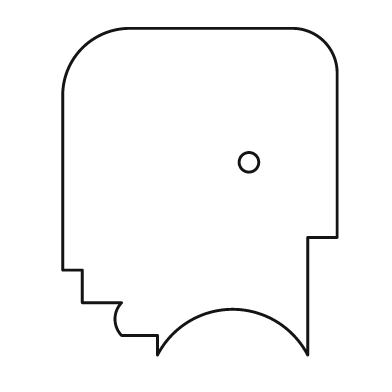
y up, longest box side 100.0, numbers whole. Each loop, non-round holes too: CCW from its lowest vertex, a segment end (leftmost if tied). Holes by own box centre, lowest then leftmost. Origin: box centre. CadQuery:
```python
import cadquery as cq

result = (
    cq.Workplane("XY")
    .moveTo(-13.0, -50.0)
    .threePointArc((10.0, -36.0), (33.0, -50.0))
    .lineTo(33.0, -14.0)
    .lineTo(42.0, -14.0)
    .lineTo(42.0, 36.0)
    .threePointArc((38.0, 46.0), (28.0, 50.0))
    .lineTo(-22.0, 50.0)
    .threePointArc((-36.0, 44.0), (-42.0, 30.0))
    .lineTo(-42.0, -24.0)
    .lineTo(-36.0, -24.0)
    .lineTo(-36.0, -34.0)
    .lineTo(-24.0, -34.0)
    .threePointArc((-26.0, -39.0), (-24.0, -44.0))
    .lineTo(-13.0, -44.0)
    .close()
    .moveTo(15.0, 9.0)
    .circle(3.0)
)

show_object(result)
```